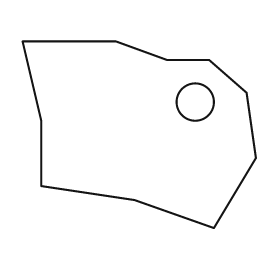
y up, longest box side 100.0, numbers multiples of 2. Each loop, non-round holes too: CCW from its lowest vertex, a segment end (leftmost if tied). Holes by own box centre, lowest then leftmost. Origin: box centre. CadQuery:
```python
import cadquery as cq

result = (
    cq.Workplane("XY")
    .moveTo(32.0, -40.0)
    .lineTo(50.0, -10.0)
    .lineTo(46.0, 18.0)
    .lineTo(30.0, 32.0)
    .lineTo(12.0, 32.0)
    .lineTo(-10.0, 40.0)
    .lineTo(-50.0, 40.0)
    .lineTo(-42.0, 6.0)
    .lineTo(-42.0, -22.0)
    .lineTo(-2.0, -28.0)
    .close()
    .moveTo(24.0, 14.0)
    .circle(8.0)
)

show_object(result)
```